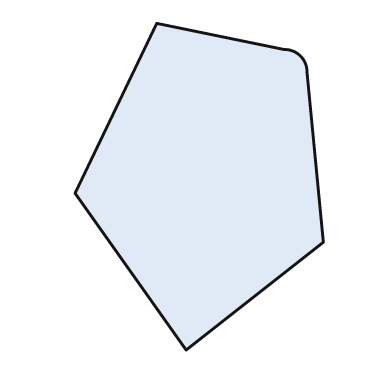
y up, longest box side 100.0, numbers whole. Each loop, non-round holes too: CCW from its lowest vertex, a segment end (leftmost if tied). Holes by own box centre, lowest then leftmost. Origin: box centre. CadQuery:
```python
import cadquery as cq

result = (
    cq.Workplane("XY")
    .moveTo(-4.0, -50.0)
    .lineTo(38.0, -17.0)
    .lineTo(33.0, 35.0)
    .threePointArc((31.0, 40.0), (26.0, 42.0))
    .lineTo(-13.0, 50.0)
    .lineTo(-38.0, -2.0)
    .close()
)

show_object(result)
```